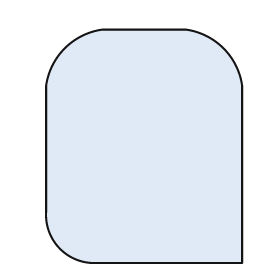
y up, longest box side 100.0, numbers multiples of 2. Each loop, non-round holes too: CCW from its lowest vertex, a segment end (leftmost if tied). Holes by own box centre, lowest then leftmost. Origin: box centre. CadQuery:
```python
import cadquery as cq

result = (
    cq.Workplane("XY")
    .moveTo(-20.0, -50.0)
    .lineTo(42.0, -50.0)
    .lineTo(42.0, 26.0)
    .threePointArc((34.0, 42.0), (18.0, 50.0))
    .lineTo(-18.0, 50.0)
    .threePointArc((-34.0, 42.0), (-42.0, 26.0))
    .lineTo(-42.0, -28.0)
    .threePointArc((-36.0, -44.0), (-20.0, -50.0))
    .close()
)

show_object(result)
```